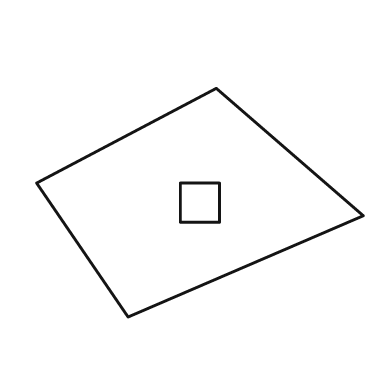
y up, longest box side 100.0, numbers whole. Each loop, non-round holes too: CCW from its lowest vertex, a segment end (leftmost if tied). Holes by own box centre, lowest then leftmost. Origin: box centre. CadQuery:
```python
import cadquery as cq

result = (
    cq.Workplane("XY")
    .moveTo(-22.0, -35.0)
    .lineTo(50.0, -4.0)
    .lineTo(5.0, 35.0)
    .lineTo(-50.0, 6.0)
    .close()
    .moveTo(-6.0, -6.0)
    .lineTo(6.0, -6.0)
    .lineTo(6.0, 6.0)
    .lineTo(-6.0, 6.0)
    .close()
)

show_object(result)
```